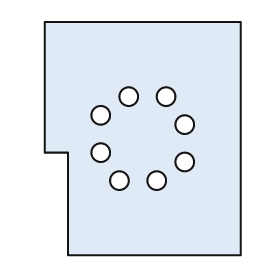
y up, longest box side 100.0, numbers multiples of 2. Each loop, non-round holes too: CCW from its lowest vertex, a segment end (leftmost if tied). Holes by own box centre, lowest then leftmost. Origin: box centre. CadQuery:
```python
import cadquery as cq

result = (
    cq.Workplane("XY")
    .moveTo(-32.0, -50.0)
    .lineTo(42.0, -50.0)
    .lineTo(42.0, 50.0)
    .lineTo(-42.0, 50.0)
    .lineTo(-42.0, -6.0)
    .lineTo(-32.0, -6.0)
    .close()
    .moveTo(-10.0, -18.0)
    .circle(4.0)
    .moveTo(6.0, -18.0)
    .circle(4.0)
    .moveTo(18.0, -10.0)
    .circle(4.0)
    .moveTo(-18.0, -6.0)
    .circle(4.0)
    .moveTo(18.0, 6.0)
    .circle(4.0)
    .moveTo(-18.0, 10.0)
    .circle(4.0)
    .moveTo(-6.0, 18.0)
    .circle(4.0)
    .moveTo(10.0, 18.0)
    .circle(4.0)
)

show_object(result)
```